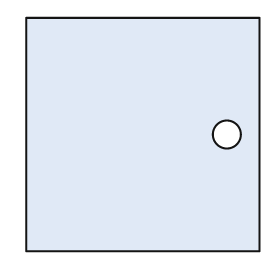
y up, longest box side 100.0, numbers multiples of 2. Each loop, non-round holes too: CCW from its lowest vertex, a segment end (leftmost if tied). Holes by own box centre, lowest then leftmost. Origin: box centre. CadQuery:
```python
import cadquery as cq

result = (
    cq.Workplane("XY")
    .moveTo(-50.0, -50.0)
    .lineTo(50.0, -50.0)
    .lineTo(50.0, 50.0)
    .lineTo(-50.0, 50.0)
    .close()
    .moveTo(36.0, 0.0)
    .circle(6.0)
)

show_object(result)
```